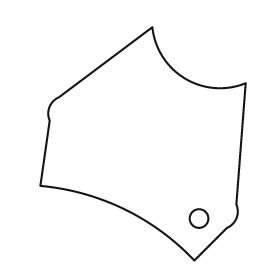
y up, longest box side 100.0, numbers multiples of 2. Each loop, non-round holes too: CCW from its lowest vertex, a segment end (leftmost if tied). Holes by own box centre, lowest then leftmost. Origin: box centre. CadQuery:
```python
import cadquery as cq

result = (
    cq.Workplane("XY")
    .moveTo(22.0, -50.0)
    .lineTo(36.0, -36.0)
    .threePointArc((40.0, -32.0), (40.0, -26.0))
    .lineTo(44.0, 26.0)
    .threePointArc((18.0, 28.0), (4.0, 50.0))
    .lineTo(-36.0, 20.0)
    .threePointArc((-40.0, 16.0), (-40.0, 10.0))
    .lineTo(-44.0, -18.0)
    .threePointArc((-8.0, -28.0), (22.0, -50.0))
    .close()
    .moveTo(24.0, -32.0)
    .circle(4.0)
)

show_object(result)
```